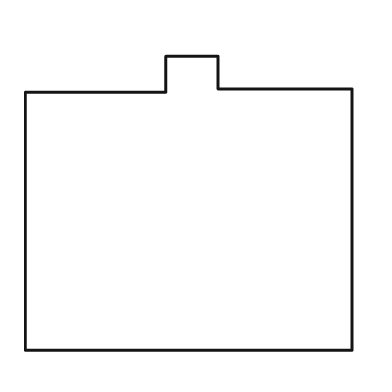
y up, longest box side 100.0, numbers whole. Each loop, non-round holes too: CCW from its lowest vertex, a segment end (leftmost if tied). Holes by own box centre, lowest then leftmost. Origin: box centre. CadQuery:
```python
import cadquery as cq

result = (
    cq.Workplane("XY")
    .moveTo(-50.0, -45.0)
    .lineTo(50.0, -45.0)
    .lineTo(50.0, 35.0)
    .lineTo(9.0, 35.0)
    .lineTo(9.0, 45.0)
    .lineTo(-7.0, 45.0)
    .lineTo(-7.0, 34.0)
    .lineTo(-50.0, 34.0)
    .close()
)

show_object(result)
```